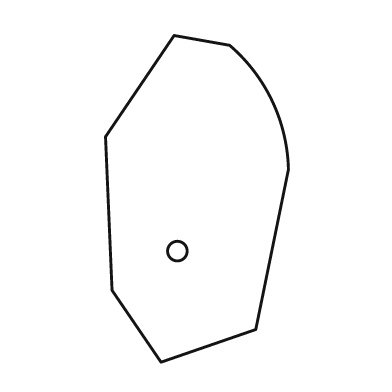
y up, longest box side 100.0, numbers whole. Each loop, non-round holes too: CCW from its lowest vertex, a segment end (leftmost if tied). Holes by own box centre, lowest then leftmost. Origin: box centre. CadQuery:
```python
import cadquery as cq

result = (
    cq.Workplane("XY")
    .moveTo(-11.0, -50.0)
    .lineTo(18.0, -40.0)
    .lineTo(28.0, 9.0)
    .threePointArc((23.0, 30.0), (10.0, 47.0))
    .lineTo(-7.0, 50.0)
    .lineTo(-28.0, 19.0)
    .lineTo(-26.0, -28.0)
    .close()
    .moveTo(-6.0, -16.0)
    .circle(3.0)
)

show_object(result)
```